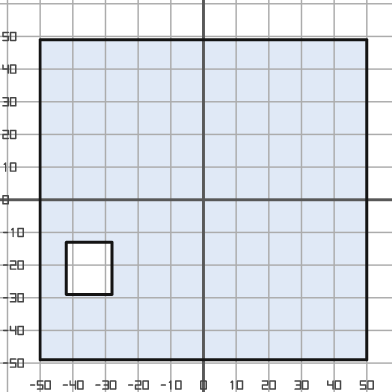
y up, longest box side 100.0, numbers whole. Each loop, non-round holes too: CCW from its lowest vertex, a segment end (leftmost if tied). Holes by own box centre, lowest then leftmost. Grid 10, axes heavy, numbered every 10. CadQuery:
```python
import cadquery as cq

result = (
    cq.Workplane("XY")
    .moveTo(-50.0, -49.0)
    .lineTo(50.0, -49.0)
    .lineTo(50.0, 49.0)
    .lineTo(-50.0, 49.0)
    .close()
    .moveTo(-42.0, -29.0)
    .lineTo(-28.0, -29.0)
    .lineTo(-28.0, -13.0)
    .lineTo(-42.0, -13.0)
    .close()
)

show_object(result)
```